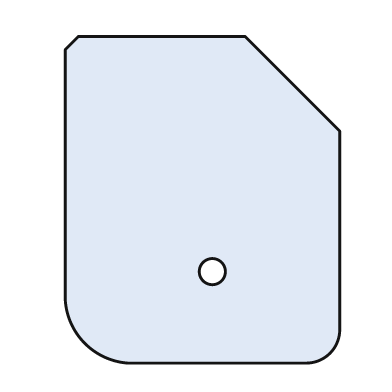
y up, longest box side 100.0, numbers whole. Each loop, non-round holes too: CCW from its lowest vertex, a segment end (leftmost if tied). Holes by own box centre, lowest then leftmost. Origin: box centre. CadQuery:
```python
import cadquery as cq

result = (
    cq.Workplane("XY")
    .moveTo(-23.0, -50.0)
    .lineTo(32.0, -50.0)
    .threePointArc((39.0, -47.0), (42.0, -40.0))
    .lineTo(42.0, 21.0)
    .lineTo(13.0, 50.0)
    .lineTo(-38.0, 50.0)
    .lineTo(-42.0, 46.0)
    .lineTo(-42.0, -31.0)
    .threePointArc((-36.0, -44.0), (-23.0, -50.0))
    .close()
    .moveTo(3.0, -22.0)
    .circle(4.0)
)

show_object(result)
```